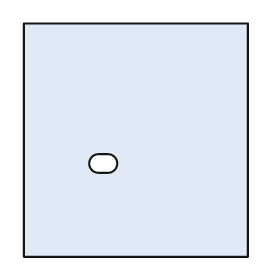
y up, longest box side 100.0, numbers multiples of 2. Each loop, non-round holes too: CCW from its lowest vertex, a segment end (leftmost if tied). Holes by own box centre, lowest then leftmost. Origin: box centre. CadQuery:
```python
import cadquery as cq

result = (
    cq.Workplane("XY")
    .moveTo(-48.0, -50.0)
    .lineTo(48.0, -50.0)
    .lineTo(48.0, 50.0)
    .lineTo(-48.0, 50.0)
    .close()
    .moveTo(-16.0, -14.0)
    .lineTo(-12.0, -14.0)
    .threePointArc((-8.0, -10.0), (-12.0, -6.0))
    .lineTo(-16.0, -6.0)
    .threePointArc((-20.0, -10.0), (-16.0, -14.0))
    .close()
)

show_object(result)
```